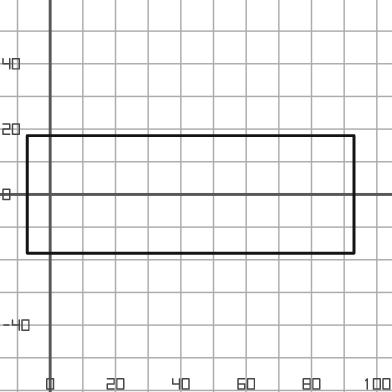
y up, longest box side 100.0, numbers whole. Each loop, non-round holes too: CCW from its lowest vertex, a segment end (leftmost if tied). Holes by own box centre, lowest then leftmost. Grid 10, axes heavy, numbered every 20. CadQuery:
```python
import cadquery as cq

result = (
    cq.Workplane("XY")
    .moveTo(-7.0, -18.0)
    .lineTo(93.0, -18.0)
    .lineTo(93.0, 18.0)
    .lineTo(-7.0, 18.0)
    .close()
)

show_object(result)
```